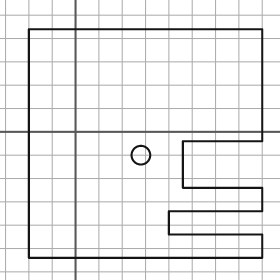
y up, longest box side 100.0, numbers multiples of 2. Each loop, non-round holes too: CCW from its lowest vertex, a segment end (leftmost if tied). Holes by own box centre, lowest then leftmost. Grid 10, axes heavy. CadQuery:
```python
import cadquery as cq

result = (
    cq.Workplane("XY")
    .moveTo(-20.0, -54.0)
    .lineTo(80.0, -54.0)
    .lineTo(80.0, -44.0)
    .lineTo(40.0, -44.0)
    .lineTo(40.0, -34.0)
    .lineTo(80.0, -34.0)
    .lineTo(80.0, -24.0)
    .lineTo(46.0, -24.0)
    .lineTo(46.0, -4.0)
    .lineTo(80.0, -4.0)
    .lineTo(80.0, 44.0)
    .lineTo(-20.0, 44.0)
    .close()
    .moveTo(28.0, -10.0)
    .circle(4.0)
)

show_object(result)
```